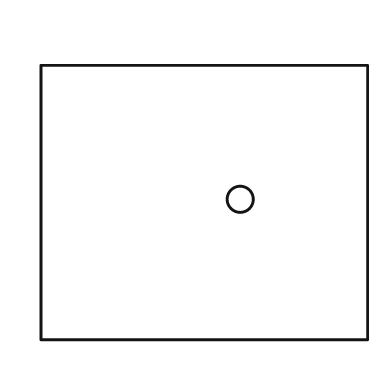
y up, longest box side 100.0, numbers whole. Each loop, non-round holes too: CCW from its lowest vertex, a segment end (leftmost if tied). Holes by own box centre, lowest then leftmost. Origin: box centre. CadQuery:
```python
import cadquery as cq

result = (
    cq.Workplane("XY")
    .moveTo(-50.0, -42.0)
    .lineTo(50.0, -42.0)
    .lineTo(50.0, 42.0)
    .lineTo(-50.0, 42.0)
    .close()
    .moveTo(11.0, 1.0)
    .circle(4.0)
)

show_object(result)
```